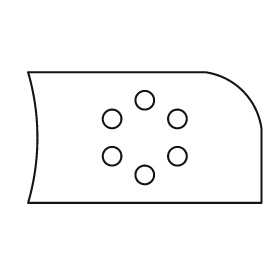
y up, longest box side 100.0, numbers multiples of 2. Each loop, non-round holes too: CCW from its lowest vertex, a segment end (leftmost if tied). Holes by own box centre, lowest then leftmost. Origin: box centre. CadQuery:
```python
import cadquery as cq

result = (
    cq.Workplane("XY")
    .moveTo(-50.0, -28.0)
    .lineTo(50.0, -28.0)
    .lineTo(50.0, 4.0)
    .threePointArc((42.0, 20.0), (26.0, 28.0))
    .lineTo(-50.0, 28.0)
    .threePointArc((-46.0, 0.0), (-50.0, -28.0))
    .close()
    .moveTo(0.0, -16.0)
    .circle(4.0)
    .moveTo(-14.0, -8.0)
    .circle(4.0)
    .moveTo(14.0, -8.0)
    .circle(4.0)
    .moveTo(-14.0, 8.0)
    .circle(4.0)
    .moveTo(14.0, 8.0)
    .circle(4.0)
    .moveTo(0.0, 16.0)
    .circle(4.0)
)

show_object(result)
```